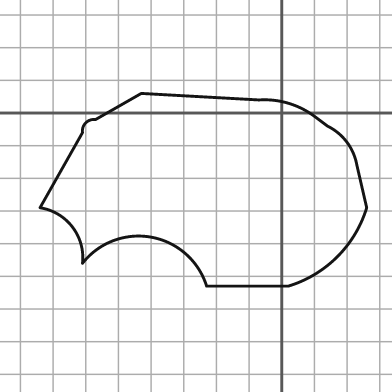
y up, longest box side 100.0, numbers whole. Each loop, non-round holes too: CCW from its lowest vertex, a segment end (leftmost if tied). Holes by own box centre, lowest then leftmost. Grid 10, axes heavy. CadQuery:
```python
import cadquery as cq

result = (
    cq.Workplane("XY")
    .moveTo(-23.0, -53.0)
    .lineTo(2.0, -53.0)
    .threePointArc((17.0, -44.0), (26.0, -29.0))
    .lineTo(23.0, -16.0)
    .threePointArc((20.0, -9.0), (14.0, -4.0))
    .lineTo(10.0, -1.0)
    .threePointArc((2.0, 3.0), (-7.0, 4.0))
    .lineTo(-43.0, 6.0)
    .lineTo(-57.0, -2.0)
    .threePointArc((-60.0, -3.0), (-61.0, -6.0))
    .lineTo(-74.0, -29.0)
    .threePointArc((-64.0, -35.0), (-61.0, -46.0))
    .threePointArc((-40.0, -38.0), (-23.0, -53.0))
    .close()
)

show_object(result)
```